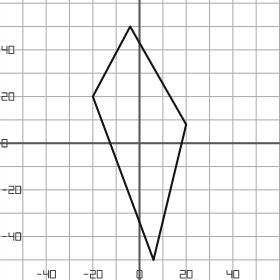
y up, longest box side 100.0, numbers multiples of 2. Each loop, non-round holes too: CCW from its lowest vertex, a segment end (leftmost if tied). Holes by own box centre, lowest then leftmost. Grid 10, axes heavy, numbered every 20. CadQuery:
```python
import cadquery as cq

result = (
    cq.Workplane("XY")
    .moveTo(6.0, -50.0)
    .lineTo(20.0, 8.0)
    .lineTo(-4.0, 50.0)
    .lineTo(-20.0, 20.0)
    .close()
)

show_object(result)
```